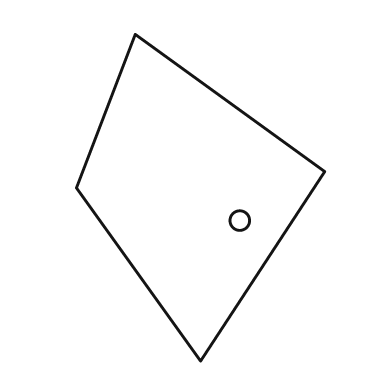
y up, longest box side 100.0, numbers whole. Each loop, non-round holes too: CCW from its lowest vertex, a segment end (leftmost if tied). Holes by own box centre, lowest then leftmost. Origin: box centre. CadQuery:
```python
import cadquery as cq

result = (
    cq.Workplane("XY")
    .moveTo(0.0, -50.0)
    .lineTo(38.0, 8.0)
    .lineTo(-20.0, 50.0)
    .lineTo(-38.0, 3.0)
    .close()
    .moveTo(12.0, -7.0)
    .circle(3.0)
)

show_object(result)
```